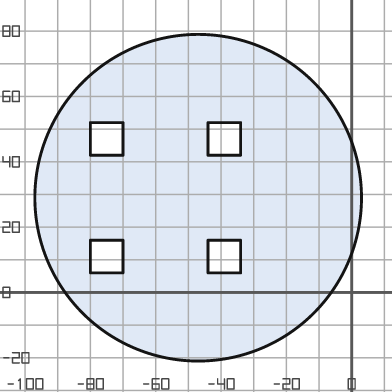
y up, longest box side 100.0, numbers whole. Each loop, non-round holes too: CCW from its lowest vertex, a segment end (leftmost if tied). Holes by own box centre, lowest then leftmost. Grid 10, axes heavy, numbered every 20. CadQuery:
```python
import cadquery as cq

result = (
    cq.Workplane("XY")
    .moveTo(-47.0, 29.0)
    .circle(50.0)
    .moveTo(-80.0, 6.0)
    .lineTo(-70.0, 6.0)
    .lineTo(-70.0, 16.0)
    .lineTo(-80.0, 16.0)
    .close()
    .moveTo(-44.0, 6.0)
    .lineTo(-34.0, 6.0)
    .lineTo(-34.0, 16.0)
    .lineTo(-44.0, 16.0)
    .close()
    .moveTo(-80.0, 42.0)
    .lineTo(-70.0, 42.0)
    .lineTo(-70.0, 52.0)
    .lineTo(-80.0, 52.0)
    .close()
    .moveTo(-44.0, 42.0)
    .lineTo(-34.0, 42.0)
    .lineTo(-34.0, 52.0)
    .lineTo(-44.0, 52.0)
    .close()
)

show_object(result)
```